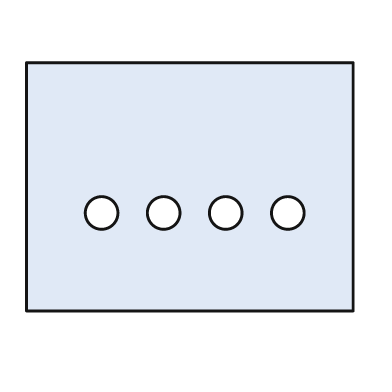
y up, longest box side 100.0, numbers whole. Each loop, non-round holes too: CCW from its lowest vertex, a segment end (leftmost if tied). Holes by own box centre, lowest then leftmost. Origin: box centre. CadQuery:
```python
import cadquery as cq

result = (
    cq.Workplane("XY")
    .moveTo(-50.0, -38.0)
    .lineTo(50.0, -38.0)
    .lineTo(50.0, 38.0)
    .lineTo(-50.0, 38.0)
    .close()
    .moveTo(-27.0, -8.0)
    .circle(5.0)
    .moveTo(-8.0, -8.0)
    .circle(5.0)
    .moveTo(11.0, -8.0)
    .circle(5.0)
    .moveTo(30.0, -8.0)
    .circle(5.0)
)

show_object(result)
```